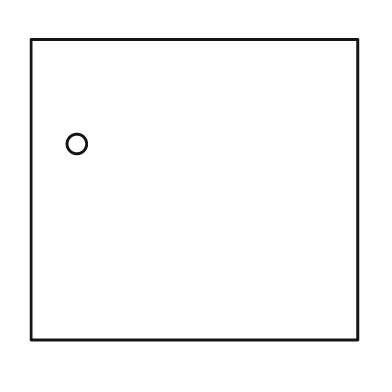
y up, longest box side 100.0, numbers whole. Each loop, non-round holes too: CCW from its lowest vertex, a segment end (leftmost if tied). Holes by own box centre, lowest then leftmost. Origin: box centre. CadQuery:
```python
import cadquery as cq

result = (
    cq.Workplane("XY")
    .moveTo(-50.0, -46.0)
    .lineTo(50.0, -46.0)
    .lineTo(50.0, 46.0)
    .lineTo(-50.0, 46.0)
    .close()
    .moveTo(-36.0, 14.0)
    .circle(3.0)
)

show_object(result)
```